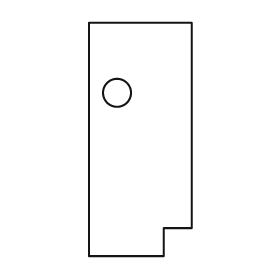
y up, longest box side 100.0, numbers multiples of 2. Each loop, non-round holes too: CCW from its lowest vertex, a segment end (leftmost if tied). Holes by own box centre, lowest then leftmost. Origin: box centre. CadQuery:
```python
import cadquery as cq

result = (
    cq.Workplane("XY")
    .moveTo(-22.0, -50.0)
    .lineTo(10.0, -50.0)
    .lineTo(10.0, -38.0)
    .lineTo(22.0, -38.0)
    .lineTo(22.0, 50.0)
    .lineTo(-22.0, 50.0)
    .close()
    .moveTo(-10.0, 20.0)
    .circle(6.0)
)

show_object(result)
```